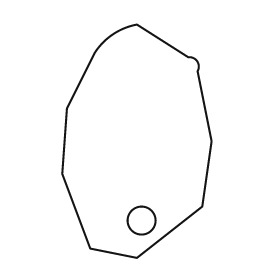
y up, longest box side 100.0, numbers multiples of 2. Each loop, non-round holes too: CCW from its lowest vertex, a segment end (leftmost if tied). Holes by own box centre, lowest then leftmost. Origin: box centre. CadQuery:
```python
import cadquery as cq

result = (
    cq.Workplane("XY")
    .moveTo(0.0, -50.0)
    .lineTo(28.0, -28.0)
    .lineTo(32.0, 0.0)
    .lineTo(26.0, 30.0)
    .threePointArc((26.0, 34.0), (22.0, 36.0))
    .lineTo(0.0, 50.0)
    .threePointArc((-10.0, 46.0), (-18.0, 38.0))
    .lineTo(-30.0, 14.0)
    .lineTo(-32.0, -14.0)
    .lineTo(-20.0, -46.0)
    .close()
    .moveTo(2.0, -34.0)
    .circle(6.0)
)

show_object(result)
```